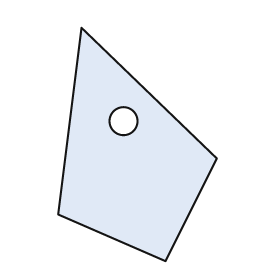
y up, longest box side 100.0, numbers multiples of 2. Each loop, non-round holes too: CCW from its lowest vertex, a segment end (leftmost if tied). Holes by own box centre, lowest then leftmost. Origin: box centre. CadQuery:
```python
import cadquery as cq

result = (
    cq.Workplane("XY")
    .moveTo(12.0, -50.0)
    .lineTo(34.0, -6.0)
    .lineTo(-24.0, 50.0)
    .lineTo(-34.0, -30.0)
    .close()
    .moveTo(-6.0, 10.0)
    .circle(6.0)
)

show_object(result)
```